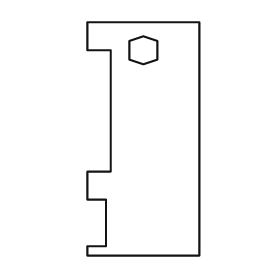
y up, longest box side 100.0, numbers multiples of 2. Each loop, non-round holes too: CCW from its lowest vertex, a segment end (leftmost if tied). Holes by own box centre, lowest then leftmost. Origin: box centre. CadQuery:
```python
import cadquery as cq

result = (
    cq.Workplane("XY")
    .moveTo(-24.0, -50.0)
    .lineTo(24.0, -50.0)
    .lineTo(24.0, 50.0)
    .lineTo(-24.0, 50.0)
    .lineTo(-24.0, 38.0)
    .lineTo(-14.0, 38.0)
    .lineTo(-14.0, -14.0)
    .lineTo(-24.0, -14.0)
    .lineTo(-24.0, -26.0)
    .lineTo(-16.0, -26.0)
    .lineTo(-16.0, -46.0)
    .lineTo(-24.0, -46.0)
    .close()
    .moveTo(0.0, 32.0)
    .lineTo(6.0, 34.0)
    .lineTo(6.0, 42.0)
    .lineTo(0.0, 44.0)
    .lineTo(-6.0, 42.0)
    .lineTo(-6.0, 34.0)
    .close()
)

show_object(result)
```